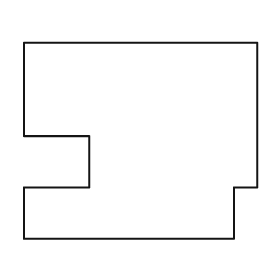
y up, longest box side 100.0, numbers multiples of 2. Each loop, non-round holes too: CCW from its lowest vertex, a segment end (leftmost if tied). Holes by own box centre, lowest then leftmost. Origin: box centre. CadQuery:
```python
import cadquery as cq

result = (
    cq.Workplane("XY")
    .moveTo(-50.0, -42.0)
    .lineTo(40.0, -42.0)
    .lineTo(40.0, -20.0)
    .lineTo(50.0, -20.0)
    .lineTo(50.0, 42.0)
    .lineTo(-50.0, 42.0)
    .lineTo(-50.0, 2.0)
    .lineTo(-22.0, 2.0)
    .lineTo(-22.0, -20.0)
    .lineTo(-50.0, -20.0)
    .close()
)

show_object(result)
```